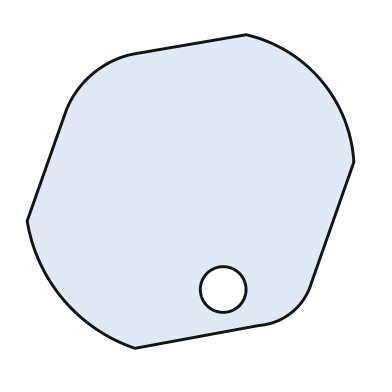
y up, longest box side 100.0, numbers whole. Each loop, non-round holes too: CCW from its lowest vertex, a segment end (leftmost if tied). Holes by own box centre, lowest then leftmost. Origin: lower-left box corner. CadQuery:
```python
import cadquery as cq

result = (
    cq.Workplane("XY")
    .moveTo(33.0, 0.0)
    .lineTo(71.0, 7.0)
    .threePointArc((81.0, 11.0), (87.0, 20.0))
    .lineTo(100.0, 57.0)
    .threePointArc((90.0, 82.0), (67.0, 96.0))
    .lineTo(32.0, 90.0)
    .threePointArc((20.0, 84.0), (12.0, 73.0))
    .lineTo(0.0, 39.0)
    .threePointArc((11.0, 15.0), (33.0, 0.0))
    .close()
    .moveTo(60.0, 18.0)
    .circle(7.0)
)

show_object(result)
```